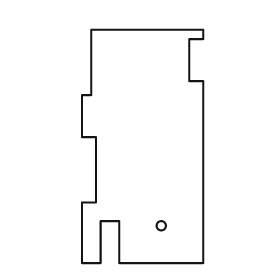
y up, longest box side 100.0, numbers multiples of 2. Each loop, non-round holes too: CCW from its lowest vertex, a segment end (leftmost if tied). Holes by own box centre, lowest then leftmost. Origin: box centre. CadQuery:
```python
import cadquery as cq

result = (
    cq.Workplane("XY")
    .moveTo(-26.0, -50.0)
    .lineTo(-18.0, -50.0)
    .lineTo(-18.0, -32.0)
    .lineTo(-10.0, -32.0)
    .lineTo(-10.0, -50.0)
    .lineTo(26.0, -50.0)
    .lineTo(26.0, 28.0)
    .lineTo(20.0, 28.0)
    .lineTo(20.0, 46.0)
    .lineTo(26.0, 46.0)
    .lineTo(26.0, 50.0)
    .lineTo(-22.0, 50.0)
    .lineTo(-22.0, 22.0)
    .lineTo(-26.0, 22.0)
    .lineTo(-26.0, 4.0)
    .lineTo(-20.0, 4.0)
    .lineTo(-20.0, -24.0)
    .lineTo(-26.0, -24.0)
    .close()
    .moveTo(8.0, -34.0)
    .circle(2.0)
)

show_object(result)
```